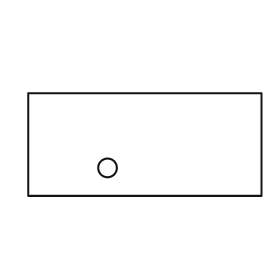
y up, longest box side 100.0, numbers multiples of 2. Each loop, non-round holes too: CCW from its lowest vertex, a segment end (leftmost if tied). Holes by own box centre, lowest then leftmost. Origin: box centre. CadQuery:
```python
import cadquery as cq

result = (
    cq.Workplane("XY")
    .moveTo(-50.0, -22.0)
    .lineTo(50.0, -22.0)
    .lineTo(50.0, 22.0)
    .lineTo(-50.0, 22.0)
    .close()
    .moveTo(-16.0, -10.0)
    .circle(4.0)
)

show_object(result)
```